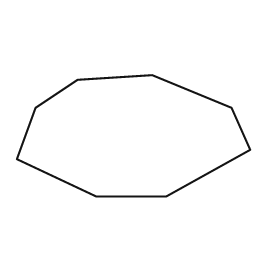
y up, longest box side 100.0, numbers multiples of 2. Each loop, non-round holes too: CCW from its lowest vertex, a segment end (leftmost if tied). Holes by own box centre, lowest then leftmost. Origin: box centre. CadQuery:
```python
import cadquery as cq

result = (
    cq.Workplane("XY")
    .moveTo(-16.0, -26.0)
    .lineTo(14.0, -26.0)
    .lineTo(50.0, -6.0)
    .lineTo(42.0, 12.0)
    .lineTo(8.0, 26.0)
    .lineTo(-24.0, 24.0)
    .lineTo(-42.0, 12.0)
    .lineTo(-50.0, -10.0)
    .close()
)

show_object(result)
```